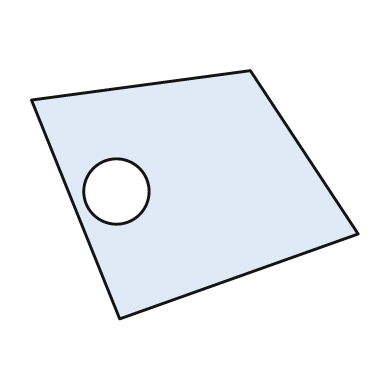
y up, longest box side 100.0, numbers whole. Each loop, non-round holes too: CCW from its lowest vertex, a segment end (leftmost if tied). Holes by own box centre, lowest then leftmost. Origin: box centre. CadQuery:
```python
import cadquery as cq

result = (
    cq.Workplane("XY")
    .moveTo(-23.0, -38.0)
    .lineTo(50.0, -12.0)
    .lineTo(17.0, 38.0)
    .lineTo(-50.0, 29.0)
    .close()
    .moveTo(-24.0, 1.0)
    .circle(10.0)
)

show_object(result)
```